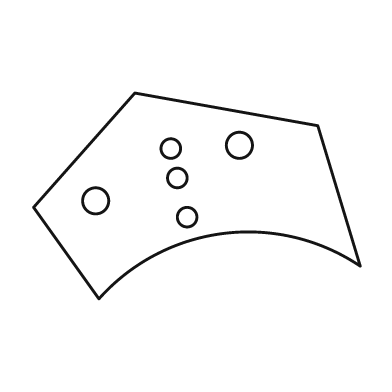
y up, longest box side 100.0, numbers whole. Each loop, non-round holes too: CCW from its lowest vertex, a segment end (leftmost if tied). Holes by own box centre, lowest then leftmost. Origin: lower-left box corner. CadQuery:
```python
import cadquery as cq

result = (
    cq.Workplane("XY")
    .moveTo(20.0, 0.0)
    .threePointArc((58.0, 20.0), (100.0, 10.0))
    .lineTo(87.0, 53.0)
    .lineTo(31.0, 63.0)
    .lineTo(0.0, 28.0)
    .close()
    .moveTo(47.0, 25.0)
    .circle(3.0)
    .moveTo(19.0, 30.0)
    .circle(4.0)
    .moveTo(44.0, 37.0)
    .circle(3.0)
    .moveTo(42.0, 46.0)
    .circle(3.0)
    .moveTo(63.0, 47.0)
    .circle(4.0)
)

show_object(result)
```